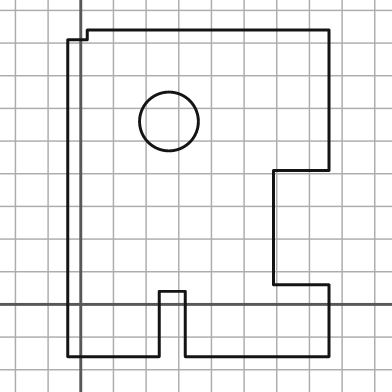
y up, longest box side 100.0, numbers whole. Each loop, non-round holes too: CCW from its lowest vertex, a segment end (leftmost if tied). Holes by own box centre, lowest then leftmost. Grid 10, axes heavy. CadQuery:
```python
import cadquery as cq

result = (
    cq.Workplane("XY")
    .moveTo(-4.0, -16.0)
    .lineTo(24.0, -16.0)
    .lineTo(24.0, 4.0)
    .lineTo(32.0, 4.0)
    .lineTo(32.0, -16.0)
    .lineTo(76.0, -16.0)
    .lineTo(76.0, 6.0)
    .lineTo(59.0, 6.0)
    .lineTo(59.0, 41.0)
    .lineTo(76.0, 41.0)
    .lineTo(76.0, 84.0)
    .lineTo(2.0, 84.0)
    .lineTo(2.0, 81.0)
    .lineTo(-4.0, 81.0)
    .close()
    .moveTo(27.0, 56.0)
    .circle(9.0)
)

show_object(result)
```